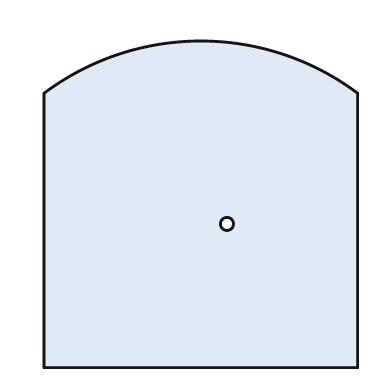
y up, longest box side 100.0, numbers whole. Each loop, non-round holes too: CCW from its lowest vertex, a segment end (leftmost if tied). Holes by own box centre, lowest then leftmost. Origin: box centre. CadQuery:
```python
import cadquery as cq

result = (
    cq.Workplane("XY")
    .moveTo(-48.0, -50.0)
    .lineTo(48.0, -50.0)
    .lineTo(48.0, 34.0)
    .threePointArc((0.0, 50.0), (-48.0, 34.0))
    .close()
    .moveTo(8.0, -6.0)
    .circle(2.0)
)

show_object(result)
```